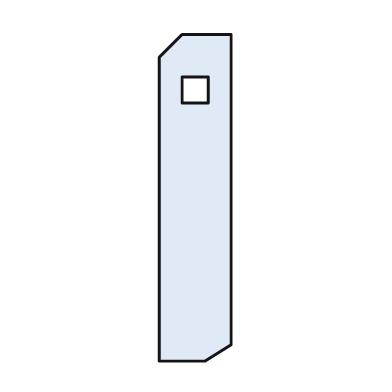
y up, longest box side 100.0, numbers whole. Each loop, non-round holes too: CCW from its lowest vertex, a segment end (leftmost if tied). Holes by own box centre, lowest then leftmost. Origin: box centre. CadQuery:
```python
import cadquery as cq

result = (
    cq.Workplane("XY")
    .moveTo(-11.0, -50.0)
    .lineTo(3.0, -50.0)
    .lineTo(11.0, -45.0)
    .lineTo(11.0, 50.0)
    .lineTo(-4.0, 50.0)
    .lineTo(-11.0, 43.0)
    .close()
    .moveTo(-4.0, 29.0)
    .lineTo(4.0, 29.0)
    .lineTo(4.0, 37.0)
    .lineTo(-4.0, 37.0)
    .close()
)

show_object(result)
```